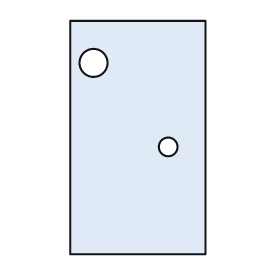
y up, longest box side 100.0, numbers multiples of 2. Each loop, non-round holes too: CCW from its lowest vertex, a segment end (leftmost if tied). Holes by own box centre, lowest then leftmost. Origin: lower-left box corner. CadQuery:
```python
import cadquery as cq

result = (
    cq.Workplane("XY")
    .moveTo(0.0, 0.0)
    .lineTo(58.0, 0.0)
    .lineTo(58.0, 100.0)
    .lineTo(0.0, 100.0)
    .close()
    .moveTo(42.0, 46.0)
    .circle(4.0)
    .moveTo(10.0, 82.0)
    .circle(6.0)
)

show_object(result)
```